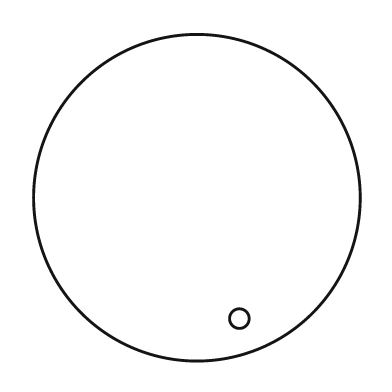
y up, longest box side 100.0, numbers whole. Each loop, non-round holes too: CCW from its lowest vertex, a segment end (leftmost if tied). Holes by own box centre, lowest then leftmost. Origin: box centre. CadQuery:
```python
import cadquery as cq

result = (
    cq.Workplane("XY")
    .moveTo(0.0, 0.0)
    .circle(50.0)
    .moveTo(13.0, -37.0)
    .circle(3.0)
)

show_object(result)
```